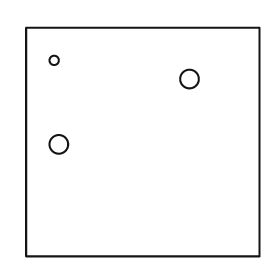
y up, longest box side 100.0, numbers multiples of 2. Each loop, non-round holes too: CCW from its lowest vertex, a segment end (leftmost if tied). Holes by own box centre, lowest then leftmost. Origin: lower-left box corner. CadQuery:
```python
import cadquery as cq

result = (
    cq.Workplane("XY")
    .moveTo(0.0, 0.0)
    .lineTo(100.0, 0.0)
    .lineTo(100.0, 98.0)
    .lineTo(0.0, 98.0)
    .close()
    .moveTo(14.0, 48.0)
    .circle(4.0)
    .moveTo(70.0, 76.0)
    .circle(4.0)
    .moveTo(12.0, 84.0)
    .circle(2.0)
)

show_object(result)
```